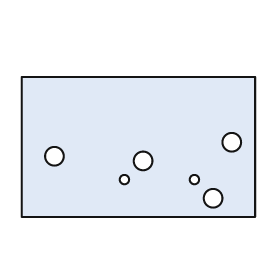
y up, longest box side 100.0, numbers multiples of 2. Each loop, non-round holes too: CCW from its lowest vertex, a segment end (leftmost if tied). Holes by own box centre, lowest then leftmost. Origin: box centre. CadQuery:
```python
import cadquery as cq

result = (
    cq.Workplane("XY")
    .moveTo(-50.0, -30.0)
    .lineTo(50.0, -30.0)
    .lineTo(50.0, 30.0)
    .lineTo(-50.0, 30.0)
    .close()
    .moveTo(32.0, -22.0)
    .circle(4.0)
    .moveTo(-6.0, -14.0)
    .circle(2.0)
    .moveTo(24.0, -14.0)
    .circle(2.0)
    .moveTo(2.0, -6.0)
    .circle(4.0)
    .moveTo(-36.0, -4.0)
    .circle(4.0)
    .moveTo(40.0, 2.0)
    .circle(4.0)
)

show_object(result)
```